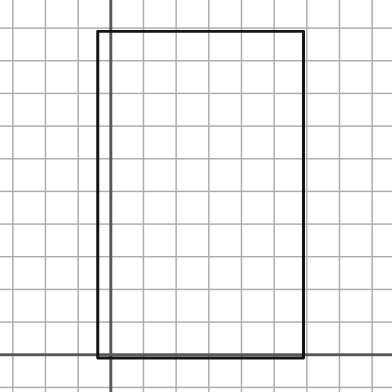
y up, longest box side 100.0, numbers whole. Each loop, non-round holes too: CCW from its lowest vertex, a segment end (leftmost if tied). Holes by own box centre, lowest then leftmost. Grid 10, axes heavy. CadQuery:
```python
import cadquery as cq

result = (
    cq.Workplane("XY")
    .moveTo(-4.0, -1.0)
    .lineTo(59.0, -1.0)
    .lineTo(59.0, 99.0)
    .lineTo(-4.0, 99.0)
    .close()
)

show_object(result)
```